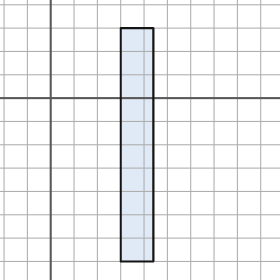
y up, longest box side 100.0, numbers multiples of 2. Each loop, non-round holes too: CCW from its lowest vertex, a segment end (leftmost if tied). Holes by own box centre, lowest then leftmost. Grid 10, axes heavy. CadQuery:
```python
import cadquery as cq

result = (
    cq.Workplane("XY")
    .moveTo(30.0, -70.0)
    .lineTo(44.0, -70.0)
    .lineTo(44.0, 30.0)
    .lineTo(30.0, 30.0)
    .close()
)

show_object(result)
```